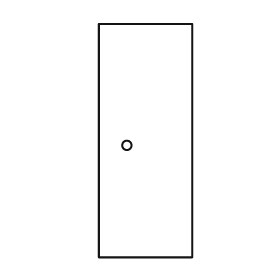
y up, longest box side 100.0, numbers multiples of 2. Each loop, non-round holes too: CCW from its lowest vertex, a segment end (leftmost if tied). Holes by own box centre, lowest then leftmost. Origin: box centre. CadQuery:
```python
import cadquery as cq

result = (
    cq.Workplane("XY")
    .moveTo(-20.0, -50.0)
    .lineTo(20.0, -50.0)
    .lineTo(20.0, 50.0)
    .lineTo(-20.0, 50.0)
    .close()
    .moveTo(-8.0, -2.0)
    .circle(2.0)
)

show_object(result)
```